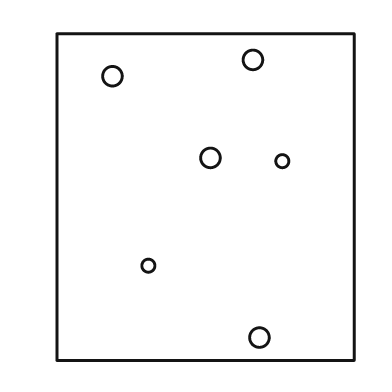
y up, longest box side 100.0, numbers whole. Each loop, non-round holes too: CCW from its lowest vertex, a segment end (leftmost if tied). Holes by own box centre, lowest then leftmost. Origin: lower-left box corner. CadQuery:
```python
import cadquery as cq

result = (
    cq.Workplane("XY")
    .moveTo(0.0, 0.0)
    .lineTo(91.0, 0.0)
    .lineTo(91.0, 100.0)
    .lineTo(0.0, 100.0)
    .close()
    .moveTo(62.0, 7.0)
    .circle(3.0)
    .moveTo(28.0, 29.0)
    .circle(2.0)
    .moveTo(69.0, 61.0)
    .circle(2.0)
    .moveTo(47.0, 62.0)
    .circle(3.0)
    .moveTo(17.0, 87.0)
    .circle(3.0)
    .moveTo(60.0, 92.0)
    .circle(3.0)
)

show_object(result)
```